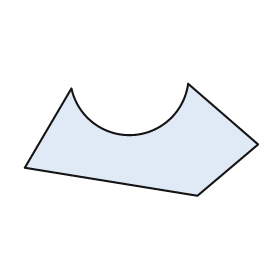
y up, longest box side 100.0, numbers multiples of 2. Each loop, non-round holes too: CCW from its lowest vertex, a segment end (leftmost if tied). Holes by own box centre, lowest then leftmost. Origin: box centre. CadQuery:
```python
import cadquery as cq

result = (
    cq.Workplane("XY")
    .moveTo(24.0, -24.0)
    .lineTo(50.0, -2.0)
    .lineTo(20.0, 24.0)
    .threePointArc((-4.0, 2.0), (-30.0, 22.0))
    .lineTo(-50.0, -12.0)
    .close()
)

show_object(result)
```